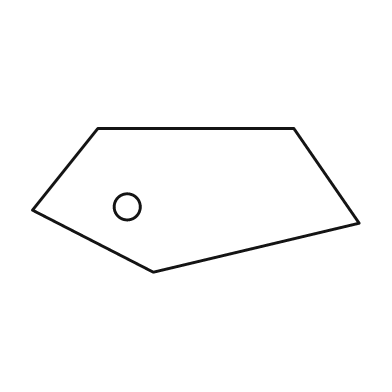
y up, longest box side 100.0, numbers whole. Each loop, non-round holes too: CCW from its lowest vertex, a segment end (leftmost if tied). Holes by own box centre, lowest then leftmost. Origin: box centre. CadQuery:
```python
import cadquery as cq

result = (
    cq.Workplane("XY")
    .moveTo(-13.0, -22.0)
    .lineTo(50.0, -7.0)
    .lineTo(30.0, 22.0)
    .lineTo(-30.0, 22.0)
    .lineTo(-50.0, -3.0)
    .close()
    .moveTo(-21.0, -2.0)
    .circle(4.0)
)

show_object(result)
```